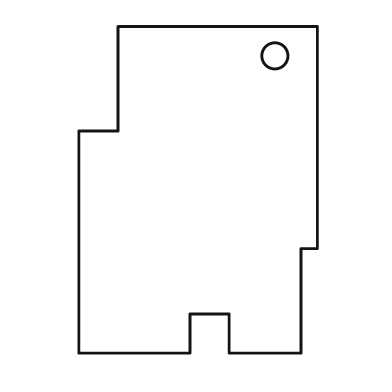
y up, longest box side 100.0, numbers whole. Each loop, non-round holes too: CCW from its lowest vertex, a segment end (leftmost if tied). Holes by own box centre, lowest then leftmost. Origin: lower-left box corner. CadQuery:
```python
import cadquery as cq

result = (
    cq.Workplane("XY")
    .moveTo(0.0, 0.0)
    .lineTo(34.0, 0.0)
    .lineTo(34.0, 12.0)
    .lineTo(46.0, 12.0)
    .lineTo(46.0, 0.0)
    .lineTo(68.0, 0.0)
    .lineTo(68.0, 32.0)
    .lineTo(73.0, 32.0)
    .lineTo(73.0, 100.0)
    .lineTo(12.0, 100.0)
    .lineTo(12.0, 68.0)
    .lineTo(0.0, 68.0)
    .close()
    .moveTo(60.0, 91.0)
    .circle(4.0)
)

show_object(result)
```